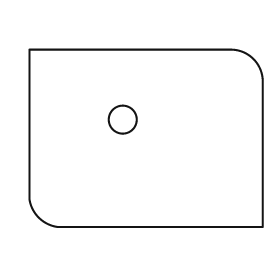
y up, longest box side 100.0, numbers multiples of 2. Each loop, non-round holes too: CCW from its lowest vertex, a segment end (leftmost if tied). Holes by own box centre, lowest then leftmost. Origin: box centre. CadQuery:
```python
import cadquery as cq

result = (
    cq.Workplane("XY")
    .moveTo(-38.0, -38.0)
    .lineTo(50.0, -38.0)
    .lineTo(50.0, 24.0)
    .threePointArc((46.0, 34.0), (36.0, 38.0))
    .lineTo(-50.0, 38.0)
    .lineTo(-50.0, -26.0)
    .threePointArc((-46.0, -34.0), (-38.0, -38.0))
    .close()
    .moveTo(-10.0, 8.0)
    .circle(6.0)
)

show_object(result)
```